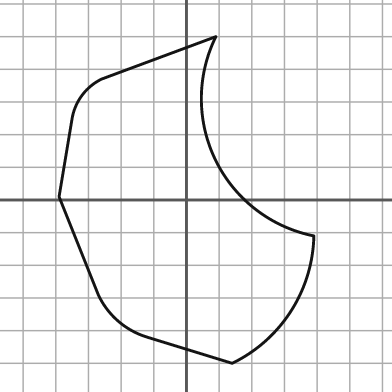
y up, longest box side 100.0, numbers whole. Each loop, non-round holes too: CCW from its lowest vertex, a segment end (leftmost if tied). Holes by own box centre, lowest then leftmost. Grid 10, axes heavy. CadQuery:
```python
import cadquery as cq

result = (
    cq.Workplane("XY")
    .moveTo(14.0, -50.0)
    .threePointArc((32.0, -34.0), (39.0, -11.0))
    .threePointArc((9.0, 12.0), (9.0, 50.0))
    .lineTo(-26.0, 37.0)
    .threePointArc((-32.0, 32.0), (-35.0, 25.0))
    .lineTo(-39.0, 1.0)
    .lineTo(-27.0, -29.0)
    .threePointArc((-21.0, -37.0), (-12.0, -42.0))
    .close()
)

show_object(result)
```